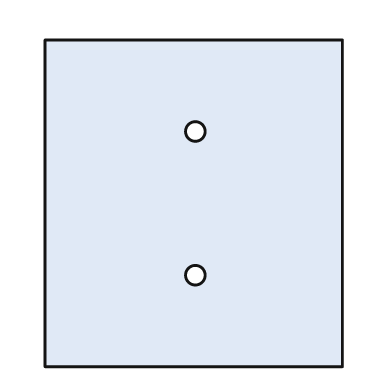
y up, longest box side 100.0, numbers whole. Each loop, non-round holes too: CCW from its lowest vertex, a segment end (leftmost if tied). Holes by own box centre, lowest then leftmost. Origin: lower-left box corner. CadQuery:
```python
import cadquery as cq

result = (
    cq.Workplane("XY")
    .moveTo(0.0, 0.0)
    .lineTo(91.0, 0.0)
    .lineTo(91.0, 100.0)
    .lineTo(0.0, 100.0)
    .close()
    .moveTo(46.0, 28.0)
    .circle(3.0)
    .moveTo(46.0, 72.0)
    .circle(3.0)
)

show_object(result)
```